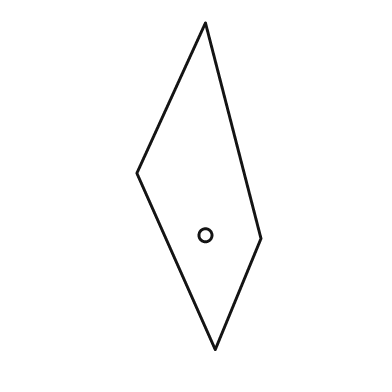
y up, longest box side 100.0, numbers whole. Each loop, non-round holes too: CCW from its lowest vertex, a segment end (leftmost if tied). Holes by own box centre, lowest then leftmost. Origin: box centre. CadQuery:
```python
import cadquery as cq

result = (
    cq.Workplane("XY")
    .moveTo(5.0, -50.0)
    .lineTo(19.0, -16.0)
    .lineTo(2.0, 50.0)
    .lineTo(-19.0, 4.0)
    .close()
    .moveTo(2.0, -15.0)
    .circle(2.0)
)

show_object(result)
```